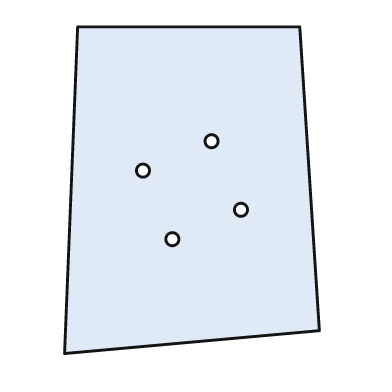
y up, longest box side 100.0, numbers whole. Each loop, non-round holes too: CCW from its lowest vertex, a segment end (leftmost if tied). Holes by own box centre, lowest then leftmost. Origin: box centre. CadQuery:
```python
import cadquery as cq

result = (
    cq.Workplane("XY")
    .moveTo(-39.0, -50.0)
    .lineTo(39.0, -43.0)
    .lineTo(33.0, 50.0)
    .lineTo(-35.0, 50.0)
    .close()
    .moveTo(-6.0, -15.0)
    .circle(2.0)
    .moveTo(15.0, -6.0)
    .circle(2.0)
    .moveTo(-15.0, 6.0)
    .circle(2.0)
    .moveTo(6.0, 15.0)
    .circle(2.0)
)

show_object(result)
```